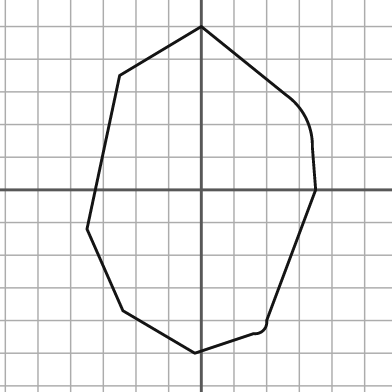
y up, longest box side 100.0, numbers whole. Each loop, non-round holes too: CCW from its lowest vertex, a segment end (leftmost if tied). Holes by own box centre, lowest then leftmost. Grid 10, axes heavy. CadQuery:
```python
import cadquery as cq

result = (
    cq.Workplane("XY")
    .moveTo(-2.0, -50.0)
    .lineTo(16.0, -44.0)
    .threePointArc((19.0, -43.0), (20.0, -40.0))
    .lineTo(35.0, 0.0)
    .lineTo(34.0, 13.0)
    .threePointArc((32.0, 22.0), (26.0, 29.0))
    .lineTo(0.0, 50.0)
    .lineTo(-25.0, 35.0)
    .lineTo(-35.0, -12.0)
    .lineTo(-24.0, -37.0)
    .close()
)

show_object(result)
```